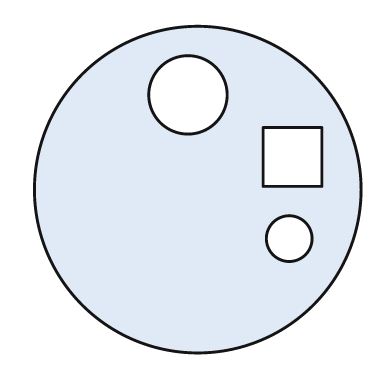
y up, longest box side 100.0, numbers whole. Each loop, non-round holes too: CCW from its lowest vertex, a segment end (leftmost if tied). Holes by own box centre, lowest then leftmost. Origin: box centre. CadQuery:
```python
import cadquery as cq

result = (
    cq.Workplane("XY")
    .moveTo(0.0, 0.0)
    .circle(50.0)
    .moveTo(28.0, -15.0)
    .circle(7.0)
    .moveTo(20.0, 1.0)
    .lineTo(38.0, 1.0)
    .lineTo(38.0, 19.0)
    .lineTo(20.0, 19.0)
    .close()
    .moveTo(-3.0, 29.0)
    .circle(12.0)
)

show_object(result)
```